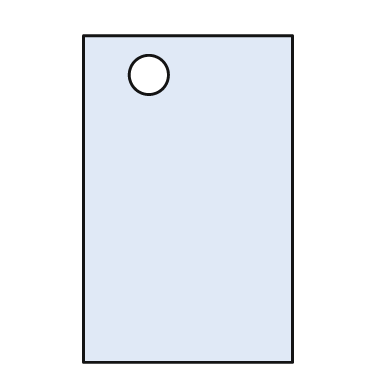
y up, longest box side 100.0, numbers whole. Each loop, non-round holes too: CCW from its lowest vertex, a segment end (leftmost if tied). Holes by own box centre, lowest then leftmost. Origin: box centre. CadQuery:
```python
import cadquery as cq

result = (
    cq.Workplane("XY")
    .moveTo(-32.0, -50.0)
    .lineTo(32.0, -50.0)
    .lineTo(32.0, 50.0)
    .lineTo(-32.0, 50.0)
    .close()
    .moveTo(-12.0, 38.0)
    .circle(6.0)
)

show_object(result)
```